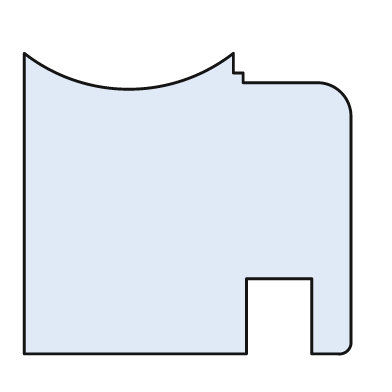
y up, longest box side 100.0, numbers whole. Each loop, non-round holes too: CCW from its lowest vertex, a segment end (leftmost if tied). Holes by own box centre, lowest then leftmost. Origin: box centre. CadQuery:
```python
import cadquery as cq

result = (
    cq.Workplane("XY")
    .moveTo(-50.0, -46.0)
    .lineTo(18.0, -46.0)
    .lineTo(18.0, -23.0)
    .lineTo(38.0, -23.0)
    .lineTo(38.0, -46.0)
    .lineTo(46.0, -46.0)
    .threePointArc((49.0, -45.0), (50.0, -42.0))
    .lineTo(50.0, 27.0)
    .threePointArc((47.0, 34.0), (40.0, 37.0))
    .lineTo(17.0, 37.0)
    .lineTo(17.0, 40.0)
    .lineTo(14.0, 40.0)
    .lineTo(14.0, 46.0)
    .threePointArc((-18.0, 35.0), (-50.0, 46.0))
    .close()
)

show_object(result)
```